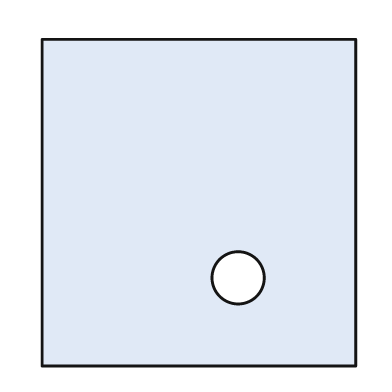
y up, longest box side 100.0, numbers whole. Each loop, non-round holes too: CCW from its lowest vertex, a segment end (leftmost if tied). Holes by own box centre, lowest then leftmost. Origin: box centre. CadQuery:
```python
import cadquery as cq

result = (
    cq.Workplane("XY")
    .moveTo(-48.0, -50.0)
    .lineTo(48.0, -50.0)
    .lineTo(48.0, 50.0)
    .lineTo(-48.0, 50.0)
    .close()
    .moveTo(12.0, -23.0)
    .circle(8.0)
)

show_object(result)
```